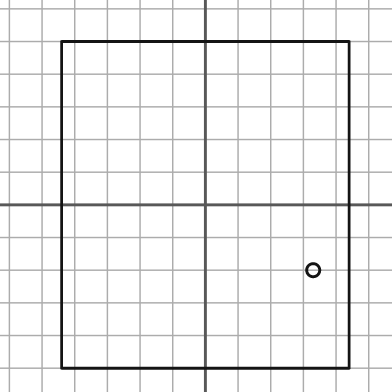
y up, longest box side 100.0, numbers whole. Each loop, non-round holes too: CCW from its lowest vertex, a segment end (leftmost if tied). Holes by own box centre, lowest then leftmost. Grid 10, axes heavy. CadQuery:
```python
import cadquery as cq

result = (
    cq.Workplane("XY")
    .moveTo(-44.0, -50.0)
    .lineTo(44.0, -50.0)
    .lineTo(44.0, 50.0)
    .lineTo(-44.0, 50.0)
    .close()
    .moveTo(33.0, -20.0)
    .circle(2.0)
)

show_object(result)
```